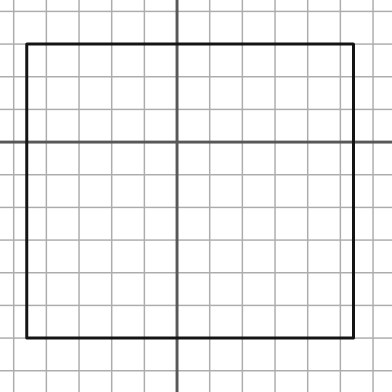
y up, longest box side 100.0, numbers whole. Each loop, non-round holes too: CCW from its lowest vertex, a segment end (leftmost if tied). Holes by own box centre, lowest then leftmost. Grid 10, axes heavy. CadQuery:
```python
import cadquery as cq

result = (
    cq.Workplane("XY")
    .moveTo(-46.0, -60.0)
    .lineTo(54.0, -60.0)
    .lineTo(54.0, 30.0)
    .lineTo(-46.0, 30.0)
    .close()
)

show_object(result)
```